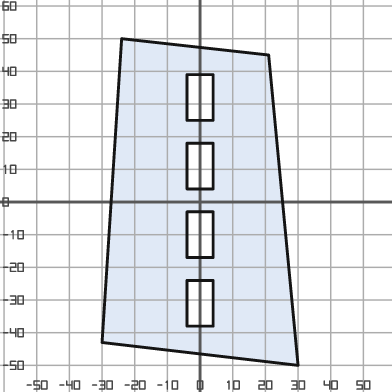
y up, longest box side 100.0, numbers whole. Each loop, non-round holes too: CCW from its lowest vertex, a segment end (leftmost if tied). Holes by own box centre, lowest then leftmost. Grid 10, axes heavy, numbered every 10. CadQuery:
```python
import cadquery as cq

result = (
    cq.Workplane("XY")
    .moveTo(30.0, -50.0)
    .lineTo(21.0, 45.0)
    .lineTo(-24.0, 50.0)
    .lineTo(-30.0, -43.0)
    .close()
    .moveTo(-4.0, -38.0)
    .lineTo(4.0, -38.0)
    .lineTo(4.0, -24.0)
    .lineTo(-4.0, -24.0)
    .close()
    .moveTo(-4.0, -17.0)
    .lineTo(4.0, -17.0)
    .lineTo(4.0, -3.0)
    .lineTo(-4.0, -3.0)
    .close()
    .moveTo(-4.0, 4.0)
    .lineTo(4.0, 4.0)
    .lineTo(4.0, 18.0)
    .lineTo(-4.0, 18.0)
    .close()
    .moveTo(-4.0, 25.0)
    .lineTo(4.0, 25.0)
    .lineTo(4.0, 39.0)
    .lineTo(-4.0, 39.0)
    .close()
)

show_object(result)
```